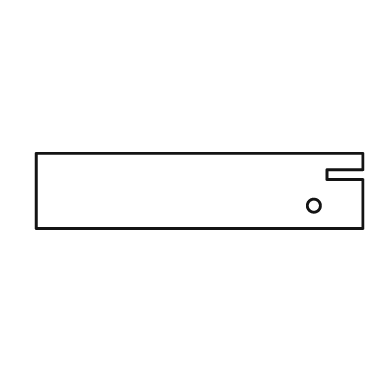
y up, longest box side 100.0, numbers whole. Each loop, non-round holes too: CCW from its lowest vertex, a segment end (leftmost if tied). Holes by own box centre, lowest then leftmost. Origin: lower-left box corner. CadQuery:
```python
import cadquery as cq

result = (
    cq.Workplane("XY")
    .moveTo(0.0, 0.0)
    .lineTo(100.0, 0.0)
    .lineTo(100.0, 15.0)
    .lineTo(89.0, 15.0)
    .lineTo(89.0, 18.0)
    .lineTo(100.0, 18.0)
    .lineTo(100.0, 23.0)
    .lineTo(0.0, 23.0)
    .close()
    .moveTo(85.0, 7.0)
    .circle(2.0)
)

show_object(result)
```